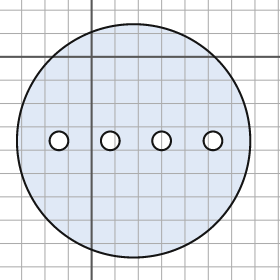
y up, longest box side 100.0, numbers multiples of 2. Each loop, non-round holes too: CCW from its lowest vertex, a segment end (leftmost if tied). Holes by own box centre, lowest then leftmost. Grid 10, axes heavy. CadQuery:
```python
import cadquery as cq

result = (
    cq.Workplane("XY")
    .moveTo(18.0, -36.0)
    .circle(50.0)
    .moveTo(-14.0, -36.0)
    .circle(4.0)
    .moveTo(8.0, -36.0)
    .circle(4.0)
    .moveTo(30.0, -36.0)
    .circle(4.0)
    .moveTo(52.0, -36.0)
    .circle(4.0)
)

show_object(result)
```